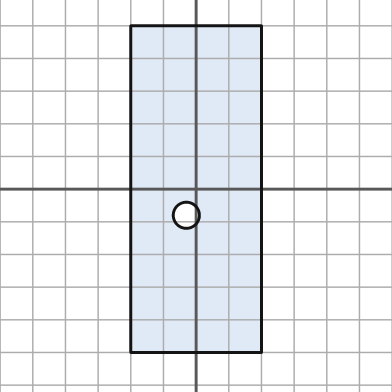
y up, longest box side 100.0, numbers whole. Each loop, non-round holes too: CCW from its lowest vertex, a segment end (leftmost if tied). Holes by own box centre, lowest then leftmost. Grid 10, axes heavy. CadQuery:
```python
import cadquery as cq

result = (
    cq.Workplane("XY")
    .moveTo(-20.0, -50.0)
    .lineTo(20.0, -50.0)
    .lineTo(20.0, 50.0)
    .lineTo(-20.0, 50.0)
    .close()
    .moveTo(-3.0, -8.0)
    .circle(4.0)
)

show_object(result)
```